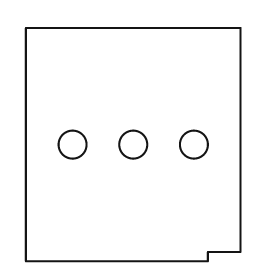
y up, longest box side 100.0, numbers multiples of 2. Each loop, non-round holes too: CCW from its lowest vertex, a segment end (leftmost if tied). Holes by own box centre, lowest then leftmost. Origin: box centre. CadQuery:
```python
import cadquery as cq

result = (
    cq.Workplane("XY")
    .moveTo(-46.0, -50.0)
    .lineTo(32.0, -50.0)
    .lineTo(32.0, -46.0)
    .lineTo(46.0, -46.0)
    .lineTo(46.0, 50.0)
    .lineTo(-46.0, 50.0)
    .close()
    .moveTo(-26.0, 0.0)
    .circle(6.0)
    .moveTo(0.0, 0.0)
    .circle(6.0)
    .moveTo(26.0, 0.0)
    .circle(6.0)
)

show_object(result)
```